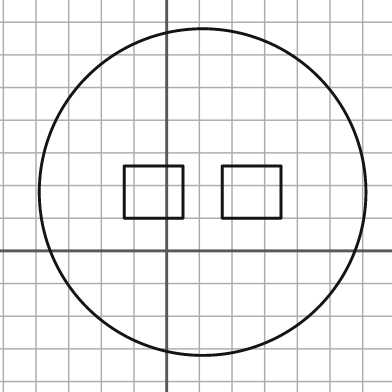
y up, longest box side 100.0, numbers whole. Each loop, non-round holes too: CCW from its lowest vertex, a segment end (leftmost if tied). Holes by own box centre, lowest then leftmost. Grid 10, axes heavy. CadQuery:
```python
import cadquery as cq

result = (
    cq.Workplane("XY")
    .moveTo(11.0, 18.0)
    .circle(50.0)
    .moveTo(-13.0, 10.0)
    .lineTo(5.0, 10.0)
    .lineTo(5.0, 26.0)
    .lineTo(-13.0, 26.0)
    .close()
    .moveTo(17.0, 10.0)
    .lineTo(35.0, 10.0)
    .lineTo(35.0, 26.0)
    .lineTo(17.0, 26.0)
    .close()
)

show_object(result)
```